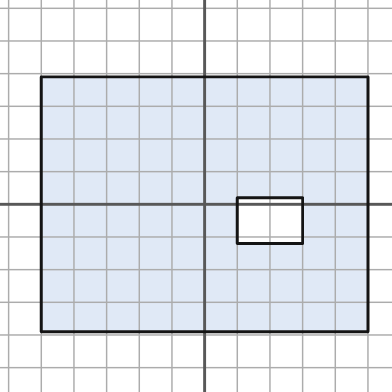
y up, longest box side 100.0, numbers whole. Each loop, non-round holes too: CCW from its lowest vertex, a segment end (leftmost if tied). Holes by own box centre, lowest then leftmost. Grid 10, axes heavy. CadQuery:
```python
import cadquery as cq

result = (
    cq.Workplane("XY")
    .moveTo(-50.0, -39.0)
    .lineTo(50.0, -39.0)
    .lineTo(50.0, 39.0)
    .lineTo(-50.0, 39.0)
    .close()
    .moveTo(10.0, -12.0)
    .lineTo(30.0, -12.0)
    .lineTo(30.0, 2.0)
    .lineTo(10.0, 2.0)
    .close()
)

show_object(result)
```